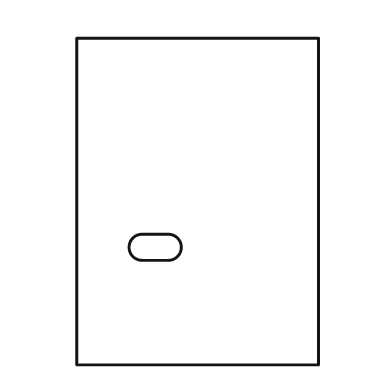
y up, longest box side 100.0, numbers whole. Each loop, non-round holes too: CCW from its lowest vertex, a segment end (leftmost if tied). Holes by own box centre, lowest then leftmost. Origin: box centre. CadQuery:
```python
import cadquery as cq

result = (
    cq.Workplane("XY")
    .moveTo(-37.0, -50.0)
    .lineTo(37.0, -50.0)
    .lineTo(37.0, 50.0)
    .lineTo(-37.0, 50.0)
    .close()
    .moveTo(-17.0, -18.0)
    .lineTo(-9.0, -18.0)
    .threePointArc((-5.0, -14.0), (-9.0, -10.0))
    .lineTo(-17.0, -10.0)
    .threePointArc((-21.0, -14.0), (-17.0, -18.0))
    .close()
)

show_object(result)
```